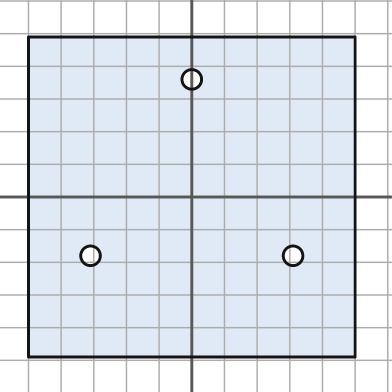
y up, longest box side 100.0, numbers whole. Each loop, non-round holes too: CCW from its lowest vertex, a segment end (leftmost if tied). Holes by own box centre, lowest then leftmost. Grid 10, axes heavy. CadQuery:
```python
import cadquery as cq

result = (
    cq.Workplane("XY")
    .moveTo(-50.0, -49.0)
    .lineTo(50.0, -49.0)
    .lineTo(50.0, 49.0)
    .lineTo(-50.0, 49.0)
    .close()
    .moveTo(-31.0, -18.0)
    .circle(3.0)
    .moveTo(31.0, -18.0)
    .circle(3.0)
    .moveTo(0.0, 36.0)
    .circle(3.0)
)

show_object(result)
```